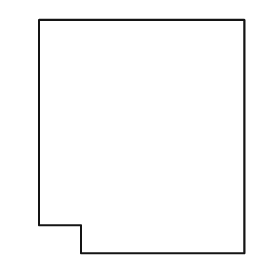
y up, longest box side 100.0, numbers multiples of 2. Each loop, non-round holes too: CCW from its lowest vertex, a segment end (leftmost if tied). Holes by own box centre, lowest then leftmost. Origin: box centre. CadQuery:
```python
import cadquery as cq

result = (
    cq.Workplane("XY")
    .moveTo(-26.0, -50.0)
    .lineTo(44.0, -50.0)
    .lineTo(44.0, 50.0)
    .lineTo(-44.0, 50.0)
    .lineTo(-44.0, -38.0)
    .lineTo(-26.0, -38.0)
    .close()
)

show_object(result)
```